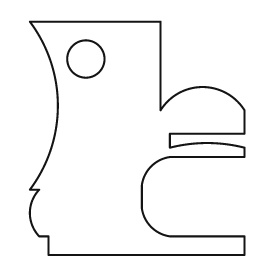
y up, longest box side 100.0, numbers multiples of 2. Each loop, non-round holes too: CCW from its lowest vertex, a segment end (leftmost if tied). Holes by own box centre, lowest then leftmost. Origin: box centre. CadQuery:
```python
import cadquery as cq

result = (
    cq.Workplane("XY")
    .moveTo(-38.0, -50.0)
    .lineTo(46.0, -50.0)
    .lineTo(46.0, -42.0)
    .lineTo(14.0, -42.0)
    .threePointArc((6.0, -38.0), (2.0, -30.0))
    .lineTo(2.0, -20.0)
    .threePointArc((6.0, -12.0), (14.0, -8.0))
    .lineTo(46.0, -8.0)
    .lineTo(46.0, -4.0)
    .threePointArc((30.0, -2.0), (14.0, -4.0))
    .lineTo(14.0, 2.0)
    .lineTo(46.0, 2.0)
    .lineTo(46.0, 12.0)
    .threePointArc((28.0, 22.0), (10.0, 12.0))
    .lineTo(10.0, 50.0)
    .lineTo(-46.0, 50.0)
    .threePointArc((-34.0, 14.0), (-46.0, -22.0))
    .lineTo(-42.0, -22.0)
    .threePointArc((-46.0, -32.0), (-42.0, -42.0))
    .lineTo(-38.0, -42.0)
    .close()
    .moveTo(-22.0, 34.0)
    .circle(8.0)
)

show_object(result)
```